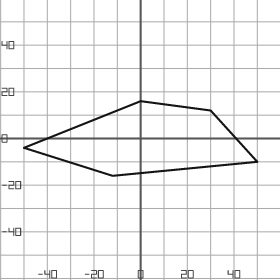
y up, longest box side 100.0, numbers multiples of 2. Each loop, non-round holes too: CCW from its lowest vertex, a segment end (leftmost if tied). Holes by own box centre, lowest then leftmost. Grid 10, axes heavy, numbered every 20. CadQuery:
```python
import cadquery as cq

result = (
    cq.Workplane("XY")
    .moveTo(-12.0, -16.0)
    .lineTo(50.0, -10.0)
    .lineTo(30.0, 12.0)
    .lineTo(0.0, 16.0)
    .lineTo(-50.0, -4.0)
    .close()
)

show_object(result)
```